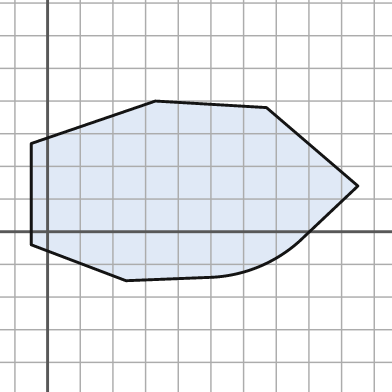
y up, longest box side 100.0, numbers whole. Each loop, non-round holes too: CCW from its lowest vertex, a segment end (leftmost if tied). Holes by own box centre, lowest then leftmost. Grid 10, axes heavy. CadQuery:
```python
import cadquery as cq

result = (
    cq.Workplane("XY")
    .moveTo(24.0, -15.0)
    .lineTo(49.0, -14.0)
    .threePointArc((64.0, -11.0), (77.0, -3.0))
    .lineTo(95.0, 14.0)
    .lineTo(67.0, 38.0)
    .lineTo(33.0, 40.0)
    .lineTo(-5.0, 27.0)
    .lineTo(-5.0, -4.0)
    .close()
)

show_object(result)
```